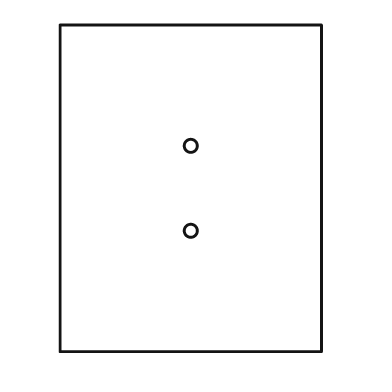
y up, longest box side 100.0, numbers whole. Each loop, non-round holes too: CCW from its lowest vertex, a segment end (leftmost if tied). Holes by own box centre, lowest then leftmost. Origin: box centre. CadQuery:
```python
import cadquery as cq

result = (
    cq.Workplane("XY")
    .moveTo(-40.0, -50.0)
    .lineTo(40.0, -50.0)
    .lineTo(40.0, 50.0)
    .lineTo(-40.0, 50.0)
    .close()
    .moveTo(0.0, -13.0)
    .circle(2.0)
    .moveTo(0.0, 13.0)
    .circle(2.0)
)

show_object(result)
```